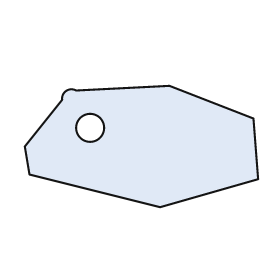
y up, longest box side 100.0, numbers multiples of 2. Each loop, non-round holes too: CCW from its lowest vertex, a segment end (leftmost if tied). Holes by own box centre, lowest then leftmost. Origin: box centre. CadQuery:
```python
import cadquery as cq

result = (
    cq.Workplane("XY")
    .moveTo(8.0, -26.0)
    .lineTo(50.0, -14.0)
    .lineTo(48.0, 12.0)
    .lineTo(12.0, 26.0)
    .lineTo(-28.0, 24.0)
    .threePointArc((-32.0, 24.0), (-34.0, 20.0))
    .lineTo(-50.0, 0.0)
    .lineTo(-48.0, -12.0)
    .close()
    .moveTo(-22.0, 8.0)
    .circle(6.0)
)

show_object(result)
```